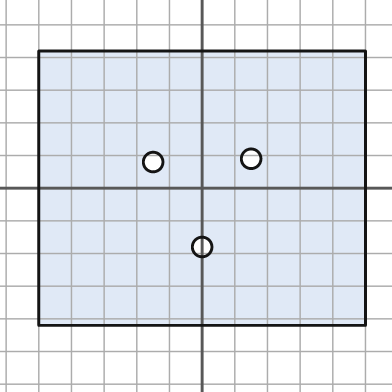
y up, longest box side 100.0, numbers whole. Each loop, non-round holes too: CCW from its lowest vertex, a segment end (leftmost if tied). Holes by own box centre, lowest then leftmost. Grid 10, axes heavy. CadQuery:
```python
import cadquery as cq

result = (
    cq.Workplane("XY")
    .moveTo(-50.0, -42.0)
    .lineTo(50.0, -42.0)
    .lineTo(50.0, 42.0)
    .lineTo(-50.0, 42.0)
    .close()
    .moveTo(0.0, -18.0)
    .circle(3.0)
    .moveTo(-15.0, 8.0)
    .circle(3.0)
    .moveTo(15.0, 9.0)
    .circle(3.0)
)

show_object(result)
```